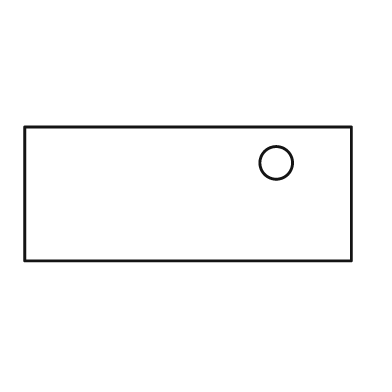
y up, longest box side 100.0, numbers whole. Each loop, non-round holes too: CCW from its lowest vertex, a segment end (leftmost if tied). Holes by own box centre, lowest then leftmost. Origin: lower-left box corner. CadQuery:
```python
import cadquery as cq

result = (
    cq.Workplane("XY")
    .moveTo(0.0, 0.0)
    .lineTo(100.0, 0.0)
    .lineTo(100.0, 41.0)
    .lineTo(0.0, 41.0)
    .close()
    .moveTo(77.0, 30.0)
    .circle(5.0)
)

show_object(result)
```